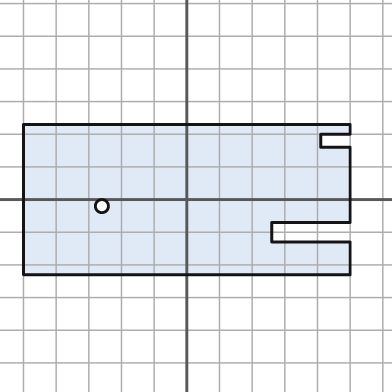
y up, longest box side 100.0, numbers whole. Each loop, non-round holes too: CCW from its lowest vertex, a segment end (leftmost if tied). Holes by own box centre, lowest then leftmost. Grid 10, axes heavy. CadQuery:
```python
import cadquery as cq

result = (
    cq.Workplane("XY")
    .moveTo(-50.0, -23.0)
    .lineTo(50.0, -23.0)
    .lineTo(50.0, -13.0)
    .lineTo(26.0, -13.0)
    .lineTo(26.0, -7.0)
    .lineTo(50.0, -7.0)
    .lineTo(50.0, 16.0)
    .lineTo(41.0, 16.0)
    .lineTo(41.0, 20.0)
    .lineTo(50.0, 20.0)
    .lineTo(50.0, 23.0)
    .lineTo(-50.0, 23.0)
    .close()
    .moveTo(-26.0, -2.0)
    .circle(2.0)
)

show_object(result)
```